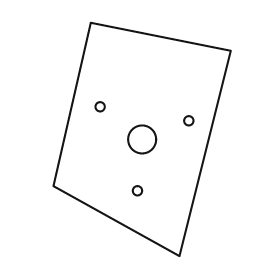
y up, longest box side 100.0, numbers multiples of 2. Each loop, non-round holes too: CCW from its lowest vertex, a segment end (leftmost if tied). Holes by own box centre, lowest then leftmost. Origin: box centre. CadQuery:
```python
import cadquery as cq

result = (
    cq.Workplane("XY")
    .moveTo(16.0, -50.0)
    .lineTo(38.0, 38.0)
    .lineTo(-22.0, 50.0)
    .lineTo(-38.0, -20.0)
    .close()
    .moveTo(-2.0, -22.0)
    .circle(2.0)
    .moveTo(0.0, 0.0)
    .circle(6.0)
    .moveTo(20.0, 8.0)
    .circle(2.0)
    .moveTo(-18.0, 14.0)
    .circle(2.0)
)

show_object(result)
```